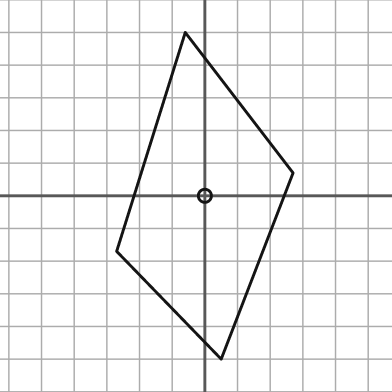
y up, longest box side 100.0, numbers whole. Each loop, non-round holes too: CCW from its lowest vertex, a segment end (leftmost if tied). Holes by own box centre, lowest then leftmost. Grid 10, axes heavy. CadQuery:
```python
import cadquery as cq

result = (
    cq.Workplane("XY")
    .moveTo(5.0, -50.0)
    .lineTo(27.0, 7.0)
    .lineTo(-6.0, 50.0)
    .lineTo(-27.0, -17.0)
    .close()
    .moveTo(0.0, 0.0)
    .circle(2.0)
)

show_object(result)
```